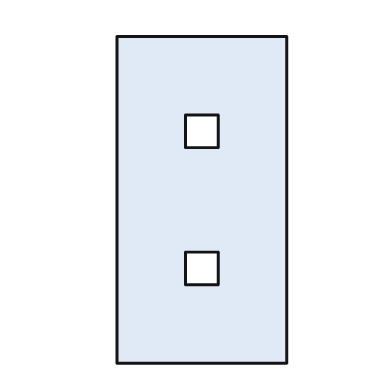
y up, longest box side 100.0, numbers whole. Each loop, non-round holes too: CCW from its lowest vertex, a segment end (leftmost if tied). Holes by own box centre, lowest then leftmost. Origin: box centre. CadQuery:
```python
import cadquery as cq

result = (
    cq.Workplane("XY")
    .moveTo(-26.0, -50.0)
    .lineTo(26.0, -50.0)
    .lineTo(26.0, 50.0)
    .lineTo(-26.0, 50.0)
    .close()
    .moveTo(-5.0, -26.0)
    .lineTo(5.0, -26.0)
    .lineTo(5.0, -16.0)
    .lineTo(-5.0, -16.0)
    .close()
    .moveTo(-5.0, 16.0)
    .lineTo(5.0, 16.0)
    .lineTo(5.0, 26.0)
    .lineTo(-5.0, 26.0)
    .close()
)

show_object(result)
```